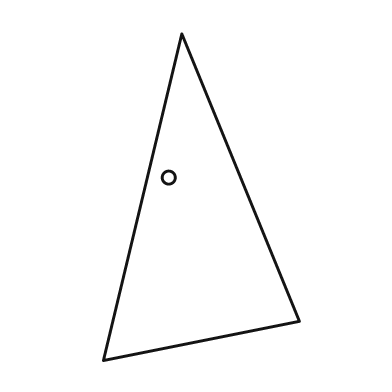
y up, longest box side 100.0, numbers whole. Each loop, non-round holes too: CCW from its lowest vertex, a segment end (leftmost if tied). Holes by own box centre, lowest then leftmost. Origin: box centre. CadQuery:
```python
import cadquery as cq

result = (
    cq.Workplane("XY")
    .moveTo(-30.0, -50.0)
    .lineTo(30.0, -38.0)
    .lineTo(-6.0, 50.0)
    .close()
    .moveTo(-10.0, 6.0)
    .circle(2.0)
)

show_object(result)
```